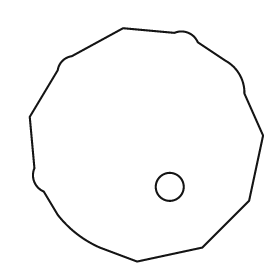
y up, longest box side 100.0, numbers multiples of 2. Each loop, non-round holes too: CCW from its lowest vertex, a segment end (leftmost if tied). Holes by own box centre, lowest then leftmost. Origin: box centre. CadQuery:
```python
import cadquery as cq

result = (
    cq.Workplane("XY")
    .moveTo(-4.0, -50.0)
    .lineTo(24.0, -44.0)
    .lineTo(44.0, -24.0)
    .lineTo(50.0, 4.0)
    .lineTo(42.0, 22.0)
    .threePointArc((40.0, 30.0), (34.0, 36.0))
    .lineTo(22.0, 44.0)
    .threePointArc((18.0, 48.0), (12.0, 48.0))
    .lineTo(-10.0, 50.0)
    .lineTo(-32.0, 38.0)
    .threePointArc((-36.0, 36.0), (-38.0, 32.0))
    .lineTo(-50.0, 12.0)
    .lineTo(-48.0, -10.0)
    .threePointArc((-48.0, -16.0), (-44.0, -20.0))
    .lineTo(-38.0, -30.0)
    .threePointArc((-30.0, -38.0), (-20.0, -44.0))
    .close()
    .moveTo(10.0, -18.0)
    .circle(6.0)
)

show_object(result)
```